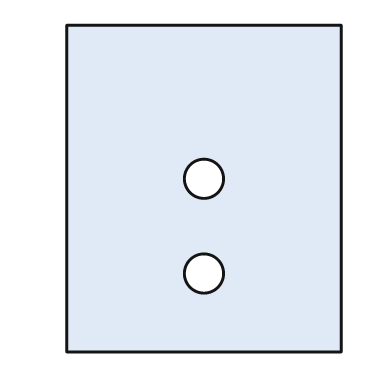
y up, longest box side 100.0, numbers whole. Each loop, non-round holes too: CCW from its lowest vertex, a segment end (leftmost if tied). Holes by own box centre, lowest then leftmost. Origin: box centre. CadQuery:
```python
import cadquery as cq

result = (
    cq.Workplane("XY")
    .moveTo(-42.0, -50.0)
    .lineTo(42.0, -50.0)
    .lineTo(42.0, 50.0)
    .lineTo(-42.0, 50.0)
    .close()
    .moveTo(0.0, -26.0)
    .circle(6.0)
    .moveTo(0.0, 3.0)
    .circle(6.0)
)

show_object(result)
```